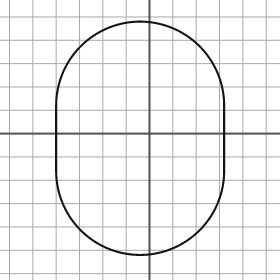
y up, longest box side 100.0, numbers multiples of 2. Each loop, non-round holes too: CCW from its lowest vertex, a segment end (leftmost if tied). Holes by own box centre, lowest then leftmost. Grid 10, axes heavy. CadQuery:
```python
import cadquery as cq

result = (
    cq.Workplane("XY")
    .moveTo(-40.0, -16.0)
    .threePointArc((-4.0, -52.0), (32.0, -16.0))
    .lineTo(32.0, 12.0)
    .threePointArc((-4.0, 48.0), (-40.0, 12.0))
    .close()
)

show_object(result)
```